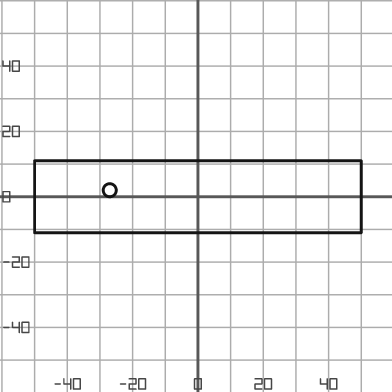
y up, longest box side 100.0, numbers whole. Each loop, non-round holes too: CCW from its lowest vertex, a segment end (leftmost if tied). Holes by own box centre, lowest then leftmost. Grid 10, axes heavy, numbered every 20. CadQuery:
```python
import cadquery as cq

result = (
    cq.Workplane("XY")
    .moveTo(-50.0, -11.0)
    .lineTo(50.0, -11.0)
    .lineTo(50.0, 11.0)
    .lineTo(-50.0, 11.0)
    .close()
    .moveTo(-27.0, 2.0)
    .circle(2.0)
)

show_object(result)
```